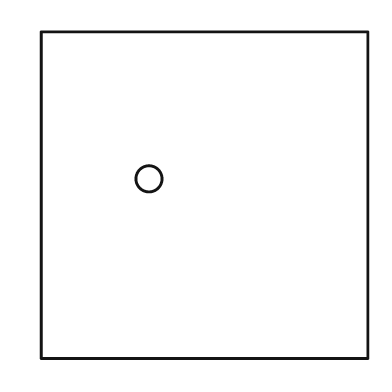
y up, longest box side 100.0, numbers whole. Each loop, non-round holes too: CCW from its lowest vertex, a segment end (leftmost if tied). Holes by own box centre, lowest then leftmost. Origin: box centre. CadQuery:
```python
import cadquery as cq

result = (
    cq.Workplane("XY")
    .moveTo(-50.0, -50.0)
    .lineTo(50.0, -50.0)
    .lineTo(50.0, 50.0)
    .lineTo(-50.0, 50.0)
    .close()
    .moveTo(-17.0, 5.0)
    .circle(4.0)
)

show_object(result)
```